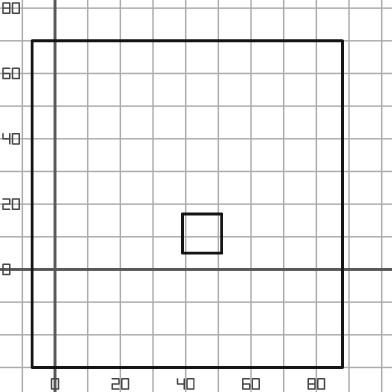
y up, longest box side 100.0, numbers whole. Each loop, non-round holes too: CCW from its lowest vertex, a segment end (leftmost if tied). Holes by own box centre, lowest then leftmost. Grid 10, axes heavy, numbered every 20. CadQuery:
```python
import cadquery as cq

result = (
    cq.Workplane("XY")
    .moveTo(-7.0, -30.0)
    .lineTo(88.0, -30.0)
    .lineTo(88.0, 70.0)
    .lineTo(-7.0, 70.0)
    .close()
    .moveTo(39.0, 5.0)
    .lineTo(51.0, 5.0)
    .lineTo(51.0, 17.0)
    .lineTo(39.0, 17.0)
    .close()
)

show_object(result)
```